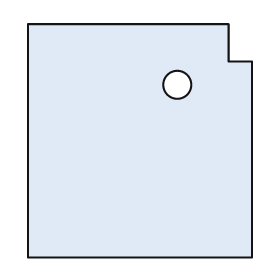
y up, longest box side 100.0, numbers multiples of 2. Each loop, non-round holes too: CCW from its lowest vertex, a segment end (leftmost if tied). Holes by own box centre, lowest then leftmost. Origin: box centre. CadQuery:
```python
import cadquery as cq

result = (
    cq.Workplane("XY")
    .moveTo(-48.0, -50.0)
    .lineTo(48.0, -50.0)
    .lineTo(48.0, 34.0)
    .lineTo(38.0, 34.0)
    .lineTo(38.0, 50.0)
    .lineTo(-48.0, 50.0)
    .close()
    .moveTo(16.0, 24.0)
    .circle(6.0)
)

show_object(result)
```